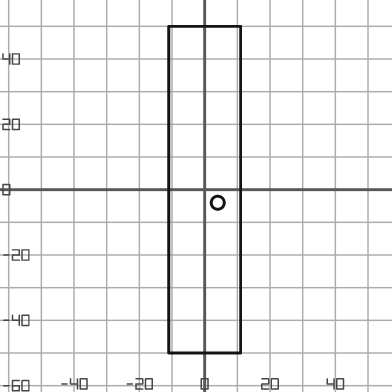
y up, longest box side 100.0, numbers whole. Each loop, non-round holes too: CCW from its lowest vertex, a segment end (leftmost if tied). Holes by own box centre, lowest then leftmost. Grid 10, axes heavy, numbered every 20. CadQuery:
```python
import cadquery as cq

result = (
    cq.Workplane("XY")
    .moveTo(-11.0, -50.0)
    .lineTo(11.0, -50.0)
    .lineTo(11.0, 50.0)
    .lineTo(-11.0, 50.0)
    .close()
    .moveTo(4.0, -4.0)
    .circle(2.0)
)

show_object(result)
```